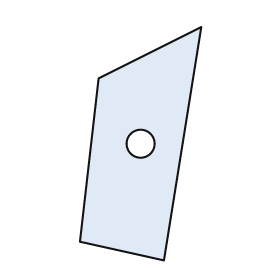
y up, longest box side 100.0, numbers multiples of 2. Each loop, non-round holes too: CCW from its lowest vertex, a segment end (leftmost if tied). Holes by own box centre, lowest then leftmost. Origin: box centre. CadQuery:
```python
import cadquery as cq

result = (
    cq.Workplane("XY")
    .moveTo(10.0, -50.0)
    .lineTo(26.0, 50.0)
    .lineTo(-18.0, 28.0)
    .lineTo(-26.0, -42.0)
    .close()
    .moveTo(0.0, 0.0)
    .circle(6.0)
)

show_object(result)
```